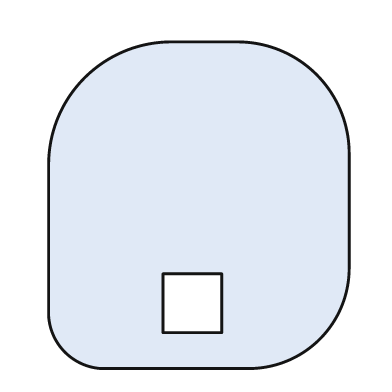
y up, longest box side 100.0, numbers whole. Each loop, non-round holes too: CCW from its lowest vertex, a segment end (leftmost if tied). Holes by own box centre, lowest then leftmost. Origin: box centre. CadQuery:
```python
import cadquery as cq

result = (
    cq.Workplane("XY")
    .moveTo(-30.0, -50.0)
    .lineTo(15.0, -50.0)
    .threePointArc((37.0, -41.0), (46.0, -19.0))
    .lineTo(46.0, 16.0)
    .threePointArc((36.0, 40.0), (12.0, 50.0))
    .lineTo(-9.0, 50.0)
    .threePointArc((-35.0, 39.0), (-46.0, 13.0))
    .lineTo(-46.0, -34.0)
    .threePointArc((-41.0, -45.0), (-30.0, -50.0))
    .close()
    .moveTo(-11.0, -39.0)
    .lineTo(7.0, -39.0)
    .lineTo(7.0, -21.0)
    .lineTo(-11.0, -21.0)
    .close()
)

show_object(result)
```